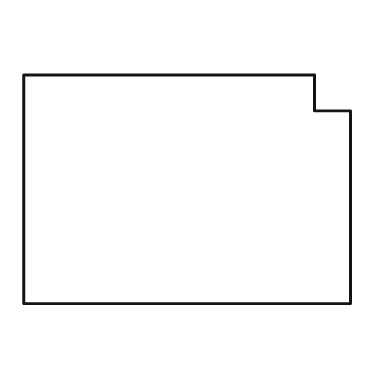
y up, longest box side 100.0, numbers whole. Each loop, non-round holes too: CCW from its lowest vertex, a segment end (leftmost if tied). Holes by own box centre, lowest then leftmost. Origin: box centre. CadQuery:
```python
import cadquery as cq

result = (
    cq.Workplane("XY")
    .moveTo(-50.0, -35.0)
    .lineTo(50.0, -35.0)
    .lineTo(50.0, 24.0)
    .lineTo(39.0, 24.0)
    .lineTo(39.0, 35.0)
    .lineTo(-50.0, 35.0)
    .close()
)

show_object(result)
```